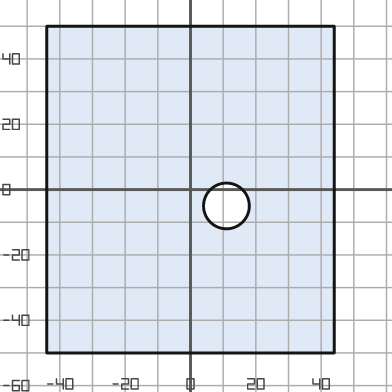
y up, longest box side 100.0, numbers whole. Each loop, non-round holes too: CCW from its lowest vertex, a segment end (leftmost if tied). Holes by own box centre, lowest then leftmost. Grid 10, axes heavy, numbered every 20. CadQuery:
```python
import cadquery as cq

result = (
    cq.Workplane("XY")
    .moveTo(-44.0, -50.0)
    .lineTo(44.0, -50.0)
    .lineTo(44.0, 50.0)
    .lineTo(-44.0, 50.0)
    .close()
    .moveTo(11.0, -5.0)
    .circle(7.0)
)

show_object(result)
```